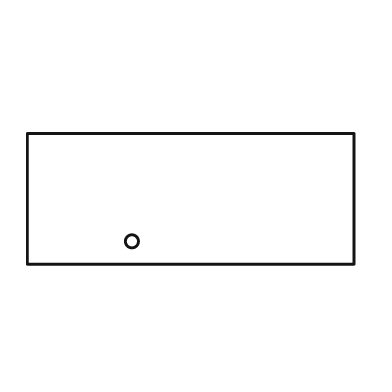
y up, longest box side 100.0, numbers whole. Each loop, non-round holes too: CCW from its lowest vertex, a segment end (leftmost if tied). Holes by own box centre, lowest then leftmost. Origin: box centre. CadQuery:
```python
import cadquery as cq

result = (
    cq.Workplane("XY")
    .moveTo(-50.0, -20.0)
    .lineTo(50.0, -20.0)
    .lineTo(50.0, 20.0)
    .lineTo(-50.0, 20.0)
    .close()
    .moveTo(-18.0, -13.0)
    .circle(2.0)
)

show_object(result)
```